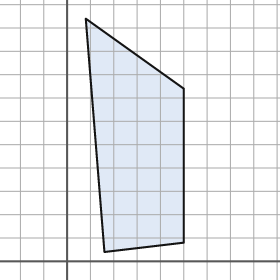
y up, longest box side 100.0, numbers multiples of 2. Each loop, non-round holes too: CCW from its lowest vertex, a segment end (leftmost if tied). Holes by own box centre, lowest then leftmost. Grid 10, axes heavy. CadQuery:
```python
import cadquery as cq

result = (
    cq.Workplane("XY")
    .moveTo(16.0, 4.0)
    .lineTo(50.0, 8.0)
    .lineTo(50.0, 74.0)
    .lineTo(8.0, 104.0)
    .close()
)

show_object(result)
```